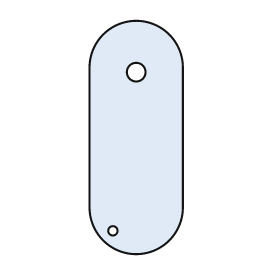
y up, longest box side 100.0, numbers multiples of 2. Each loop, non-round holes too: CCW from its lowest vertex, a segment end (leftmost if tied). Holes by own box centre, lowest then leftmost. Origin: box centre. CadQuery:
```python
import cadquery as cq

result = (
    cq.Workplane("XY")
    .moveTo(-20.0, -30.0)
    .threePointArc((0.0, -50.0), (20.0, -30.0))
    .lineTo(20.0, 30.0)
    .threePointArc((0.0, 50.0), (-20.0, 30.0))
    .close()
    .moveTo(-10.0, -40.0)
    .circle(2.0)
    .moveTo(0.0, 28.0)
    .circle(4.0)
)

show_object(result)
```